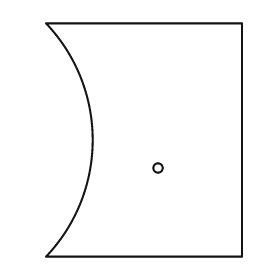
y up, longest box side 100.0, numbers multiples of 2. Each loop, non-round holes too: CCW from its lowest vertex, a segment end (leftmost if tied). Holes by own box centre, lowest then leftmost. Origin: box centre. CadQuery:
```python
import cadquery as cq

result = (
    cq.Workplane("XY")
    .moveTo(-42.0, -50.0)
    .lineTo(42.0, -50.0)
    .lineTo(42.0, 50.0)
    .lineTo(-42.0, 50.0)
    .threePointArc((-22.0, 0.0), (-42.0, -50.0))
    .close()
    .moveTo(6.0, -12.0)
    .circle(2.0)
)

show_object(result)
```